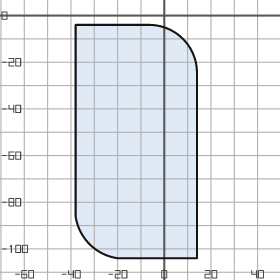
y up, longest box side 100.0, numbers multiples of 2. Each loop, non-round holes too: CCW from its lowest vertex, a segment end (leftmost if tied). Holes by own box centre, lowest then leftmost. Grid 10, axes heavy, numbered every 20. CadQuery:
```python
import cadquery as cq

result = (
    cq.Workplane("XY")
    .moveTo(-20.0, -104.0)
    .lineTo(14.0, -104.0)
    .lineTo(14.0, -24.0)
    .threePointArc((8.0, -10.0), (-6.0, -4.0))
    .lineTo(-38.0, -4.0)
    .lineTo(-38.0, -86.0)
    .threePointArc((-32.0, -98.0), (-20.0, -104.0))
    .close()
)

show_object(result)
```